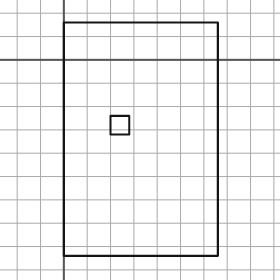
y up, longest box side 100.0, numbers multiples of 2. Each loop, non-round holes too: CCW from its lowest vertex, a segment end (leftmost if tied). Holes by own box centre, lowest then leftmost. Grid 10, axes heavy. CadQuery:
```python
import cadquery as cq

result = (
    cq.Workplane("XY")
    .moveTo(0.0, -84.0)
    .lineTo(66.0, -84.0)
    .lineTo(66.0, 16.0)
    .lineTo(0.0, 16.0)
    .close()
    .moveTo(20.0, -32.0)
    .lineTo(28.0, -32.0)
    .lineTo(28.0, -24.0)
    .lineTo(20.0, -24.0)
    .close()
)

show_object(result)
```